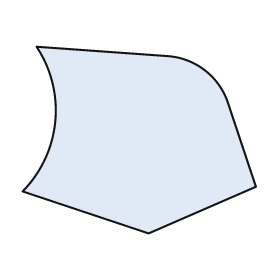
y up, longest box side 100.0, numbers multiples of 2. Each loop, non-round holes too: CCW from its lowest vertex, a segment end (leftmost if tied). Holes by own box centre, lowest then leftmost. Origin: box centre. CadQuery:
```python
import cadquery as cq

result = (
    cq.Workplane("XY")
    .moveTo(4.0, -40.0)
    .lineTo(50.0, -20.0)
    .lineTo(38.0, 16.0)
    .threePointArc((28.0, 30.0), (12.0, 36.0))
    .lineTo(-44.0, 40.0)
    .threePointArc((-36.0, 8.0), (-50.0, -22.0))
    .close()
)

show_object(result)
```